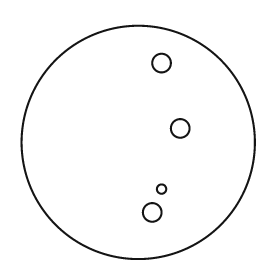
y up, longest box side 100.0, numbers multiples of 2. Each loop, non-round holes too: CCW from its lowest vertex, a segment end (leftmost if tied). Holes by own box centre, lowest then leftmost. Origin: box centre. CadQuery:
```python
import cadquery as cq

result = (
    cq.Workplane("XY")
    .moveTo(0.0, 0.0)
    .circle(50.0)
    .moveTo(6.0, -30.0)
    .circle(4.0)
    .moveTo(10.0, -20.0)
    .circle(2.0)
    .moveTo(18.0, 6.0)
    .circle(4.0)
    .moveTo(10.0, 34.0)
    .circle(4.0)
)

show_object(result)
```